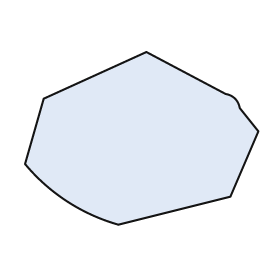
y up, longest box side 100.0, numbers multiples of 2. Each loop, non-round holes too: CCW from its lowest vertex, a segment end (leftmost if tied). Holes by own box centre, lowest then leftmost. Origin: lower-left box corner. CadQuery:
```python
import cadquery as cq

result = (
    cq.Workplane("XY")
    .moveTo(40.0, 0.0)
    .lineTo(88.0, 12.0)
    .lineTo(100.0, 40.0)
    .lineTo(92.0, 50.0)
    .threePointArc((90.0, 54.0), (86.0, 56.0))
    .lineTo(52.0, 74.0)
    .lineTo(8.0, 54.0)
    .lineTo(0.0, 26.0)
    .threePointArc((18.0, 10.0), (40.0, 0.0))
    .close()
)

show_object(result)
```